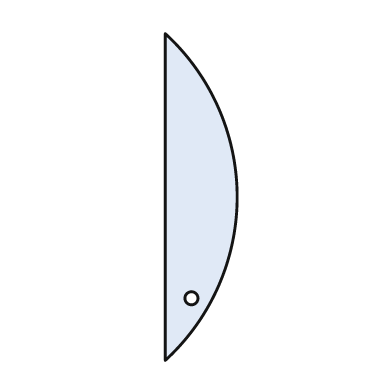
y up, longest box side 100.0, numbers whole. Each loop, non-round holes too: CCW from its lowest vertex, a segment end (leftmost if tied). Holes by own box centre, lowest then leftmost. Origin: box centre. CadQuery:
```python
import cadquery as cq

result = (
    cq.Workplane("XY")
    .moveTo(-11.0, -50.0)
    .threePointArc((11.0, 0.0), (-11.0, 50.0))
    .close()
    .moveTo(-3.0, -31.0)
    .circle(2.0)
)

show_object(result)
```